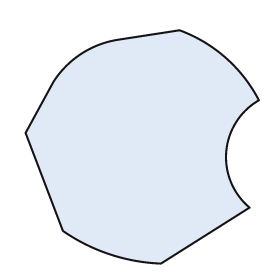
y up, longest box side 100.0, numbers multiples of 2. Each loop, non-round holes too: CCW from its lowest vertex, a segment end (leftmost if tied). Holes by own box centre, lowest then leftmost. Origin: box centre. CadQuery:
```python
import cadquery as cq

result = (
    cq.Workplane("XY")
    .moveTo(8.0, -50.0)
    .lineTo(46.0, -26.0)
    .threePointArc((36.0, -2.0), (50.0, 20.0))
    .threePointArc((36.0, 38.0), (16.0, 50.0))
    .lineTo(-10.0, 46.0)
    .threePointArc((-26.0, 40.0), (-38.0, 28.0))
    .lineTo(-50.0, 6.0)
    .lineTo(-34.0, -36.0)
    .threePointArc((-14.0, -46.0), (8.0, -50.0))
    .close()
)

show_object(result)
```